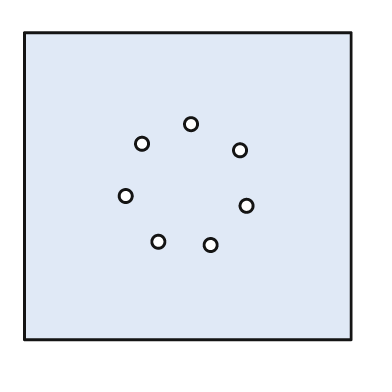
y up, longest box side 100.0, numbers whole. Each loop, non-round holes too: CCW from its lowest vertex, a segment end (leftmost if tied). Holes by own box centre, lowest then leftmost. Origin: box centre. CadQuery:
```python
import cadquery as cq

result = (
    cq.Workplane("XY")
    .moveTo(-50.0, -47.0)
    .lineTo(50.0, -47.0)
    .lineTo(50.0, 47.0)
    .lineTo(-50.0, 47.0)
    .close()
    .moveTo(7.0, -18.0)
    .circle(2.0)
    .moveTo(-9.0, -17.0)
    .circle(2.0)
    .moveTo(18.0, -6.0)
    .circle(2.0)
    .moveTo(-19.0, -3.0)
    .circle(2.0)
    .moveTo(16.0, 11.0)
    .circle(2.0)
    .moveTo(-14.0, 13.0)
    .circle(2.0)
    .moveTo(1.0, 19.0)
    .circle(2.0)
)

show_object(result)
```